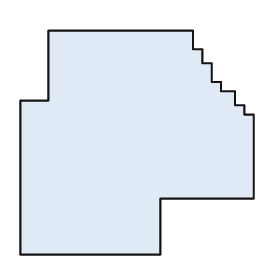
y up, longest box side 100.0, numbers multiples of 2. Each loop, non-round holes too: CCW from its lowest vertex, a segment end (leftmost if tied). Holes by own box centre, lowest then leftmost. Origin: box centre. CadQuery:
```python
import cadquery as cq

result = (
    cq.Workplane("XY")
    .moveTo(-50.0, -48.0)
    .lineTo(10.0, -48.0)
    .lineTo(10.0, -24.0)
    .lineTo(50.0, -24.0)
    .lineTo(50.0, 12.0)
    .lineTo(46.0, 12.0)
    .lineTo(46.0, 16.0)
    .lineTo(42.0, 16.0)
    .lineTo(42.0, 22.0)
    .lineTo(36.0, 22.0)
    .lineTo(36.0, 26.0)
    .lineTo(32.0, 26.0)
    .lineTo(32.0, 34.0)
    .lineTo(28.0, 34.0)
    .lineTo(28.0, 40.0)
    .lineTo(24.0, 40.0)
    .lineTo(24.0, 48.0)
    .lineTo(-38.0, 48.0)
    .lineTo(-38.0, 18.0)
    .lineTo(-50.0, 18.0)
    .close()
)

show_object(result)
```